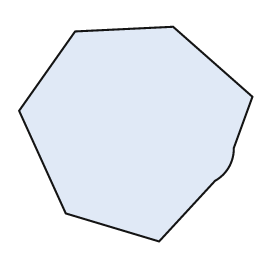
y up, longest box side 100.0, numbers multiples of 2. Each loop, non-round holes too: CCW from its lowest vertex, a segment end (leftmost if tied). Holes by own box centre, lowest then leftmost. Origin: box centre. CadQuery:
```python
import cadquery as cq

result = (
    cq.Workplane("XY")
    .moveTo(10.0, -46.0)
    .lineTo(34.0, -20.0)
    .threePointArc((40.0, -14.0), (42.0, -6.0))
    .lineTo(50.0, 16.0)
    .lineTo(16.0, 46.0)
    .lineTo(-26.0, 44.0)
    .lineTo(-50.0, 10.0)
    .lineTo(-30.0, -34.0)
    .close()
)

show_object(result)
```